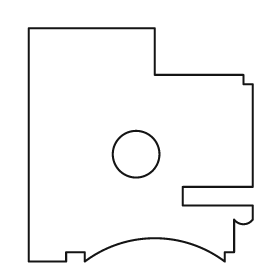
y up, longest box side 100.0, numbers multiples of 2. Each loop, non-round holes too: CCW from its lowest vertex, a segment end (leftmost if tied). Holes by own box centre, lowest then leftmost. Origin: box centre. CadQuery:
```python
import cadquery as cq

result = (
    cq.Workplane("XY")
    .moveTo(-48.0, -50.0)
    .lineTo(-32.0, -50.0)
    .lineTo(-32.0, -46.0)
    .lineTo(-24.0, -46.0)
    .lineTo(-24.0, -50.0)
    .threePointArc((6.0, -40.0), (36.0, -50.0))
    .lineTo(36.0, -46.0)
    .lineTo(40.0, -46.0)
    .lineTo(40.0, -32.0)
    .threePointArc((44.0, -34.0), (48.0, -32.0))
    .lineTo(48.0, -26.0)
    .lineTo(18.0, -26.0)
    .lineTo(18.0, -18.0)
    .lineTo(48.0, -18.0)
    .lineTo(48.0, 26.0)
    .lineTo(44.0, 26.0)
    .lineTo(44.0, 30.0)
    .lineTo(6.0, 30.0)
    .lineTo(6.0, 50.0)
    .lineTo(-48.0, 50.0)
    .close()
    .moveTo(-2.0, -4.0)
    .circle(10.0)
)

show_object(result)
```